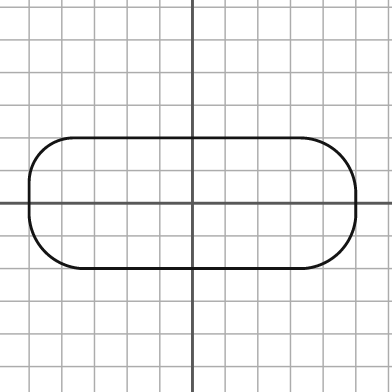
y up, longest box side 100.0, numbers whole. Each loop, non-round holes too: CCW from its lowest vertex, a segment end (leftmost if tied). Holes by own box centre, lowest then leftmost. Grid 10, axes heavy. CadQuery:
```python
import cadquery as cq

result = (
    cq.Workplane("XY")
    .moveTo(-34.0, -20.0)
    .lineTo(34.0, -20.0)
    .threePointArc((45.0, -15.0), (50.0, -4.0))
    .lineTo(50.0, 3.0)
    .threePointArc((45.0, 15.0), (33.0, 20.0))
    .lineTo(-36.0, 20.0)
    .threePointArc((-46.0, 16.0), (-50.0, 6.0))
    .lineTo(-50.0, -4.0)
    .threePointArc((-45.0, -15.0), (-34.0, -20.0))
    .close()
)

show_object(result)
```